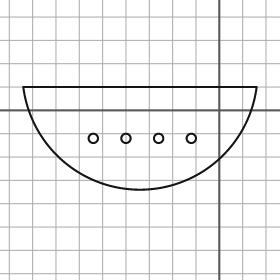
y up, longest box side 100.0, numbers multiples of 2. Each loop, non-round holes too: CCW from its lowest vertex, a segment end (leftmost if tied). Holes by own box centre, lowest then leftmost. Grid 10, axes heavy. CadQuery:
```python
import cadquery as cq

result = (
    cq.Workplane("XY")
    .moveTo(-84.0, 10.0)
    .threePointArc((-34.0, -34.0), (16.0, 10.0))
    .close()
    .moveTo(-54.0, -12.0)
    .circle(2.0)
    .moveTo(-40.0, -12.0)
    .circle(2.0)
    .moveTo(-26.0, -12.0)
    .circle(2.0)
    .moveTo(-12.0, -12.0)
    .circle(2.0)
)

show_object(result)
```